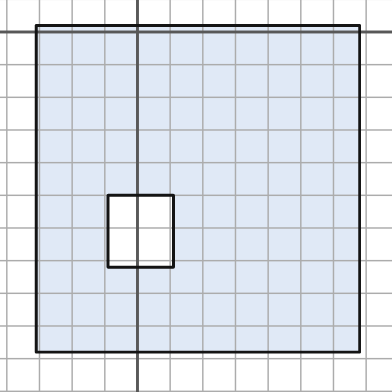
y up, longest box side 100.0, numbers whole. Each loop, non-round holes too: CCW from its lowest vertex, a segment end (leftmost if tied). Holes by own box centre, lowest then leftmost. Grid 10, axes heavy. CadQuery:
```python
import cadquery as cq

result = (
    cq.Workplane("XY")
    .moveTo(-31.0, -98.0)
    .lineTo(68.0, -98.0)
    .lineTo(68.0, 2.0)
    .lineTo(-31.0, 2.0)
    .close()
    .moveTo(-9.0, -72.0)
    .lineTo(11.0, -72.0)
    .lineTo(11.0, -50.0)
    .lineTo(-9.0, -50.0)
    .close()
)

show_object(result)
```